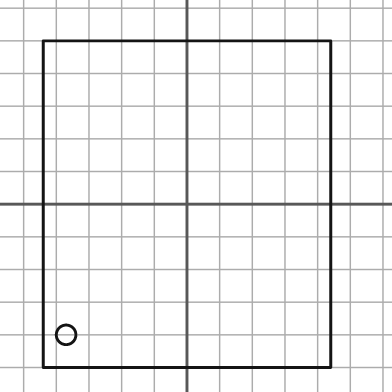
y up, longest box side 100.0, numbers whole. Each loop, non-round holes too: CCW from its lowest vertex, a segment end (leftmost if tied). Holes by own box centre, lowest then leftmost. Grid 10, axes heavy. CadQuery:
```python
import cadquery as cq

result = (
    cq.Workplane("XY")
    .moveTo(-44.0, -50.0)
    .lineTo(44.0, -50.0)
    .lineTo(44.0, 50.0)
    .lineTo(-44.0, 50.0)
    .close()
    .moveTo(-37.0, -40.0)
    .circle(3.0)
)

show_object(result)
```